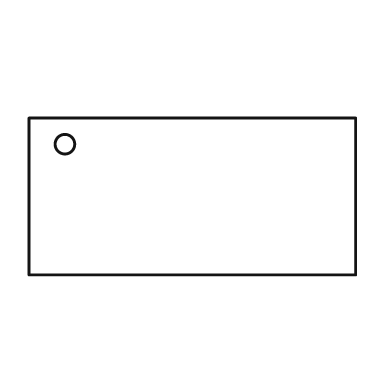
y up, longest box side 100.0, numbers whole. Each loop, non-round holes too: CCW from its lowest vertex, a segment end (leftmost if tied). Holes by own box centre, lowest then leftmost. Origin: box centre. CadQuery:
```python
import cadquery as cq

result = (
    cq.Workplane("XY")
    .moveTo(-50.0, -24.0)
    .lineTo(50.0, -24.0)
    .lineTo(50.0, 24.0)
    .lineTo(-50.0, 24.0)
    .close()
    .moveTo(-39.0, 16.0)
    .circle(3.0)
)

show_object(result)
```